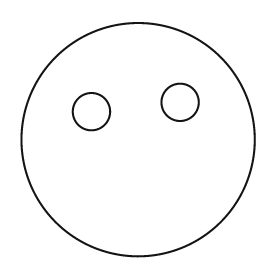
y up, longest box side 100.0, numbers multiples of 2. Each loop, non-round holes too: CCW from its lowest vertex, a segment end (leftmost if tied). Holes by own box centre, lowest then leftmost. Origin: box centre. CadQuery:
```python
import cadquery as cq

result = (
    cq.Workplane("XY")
    .moveTo(0.0, 0.0)
    .circle(50.0)
    .moveTo(-20.0, 12.0)
    .circle(8.0)
    .moveTo(18.0, 16.0)
    .circle(8.0)
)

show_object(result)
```